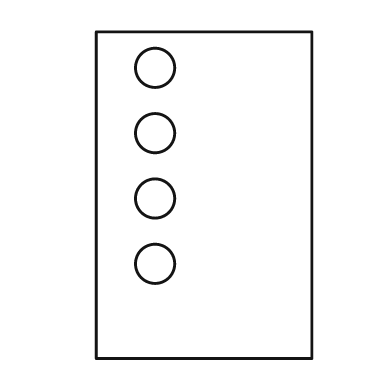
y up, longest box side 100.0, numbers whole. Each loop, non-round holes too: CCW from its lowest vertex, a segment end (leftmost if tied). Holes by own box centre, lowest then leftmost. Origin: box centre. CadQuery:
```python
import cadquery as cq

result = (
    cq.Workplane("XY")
    .moveTo(-33.0, -50.0)
    .lineTo(33.0, -50.0)
    .lineTo(33.0, 50.0)
    .lineTo(-33.0, 50.0)
    .close()
    .moveTo(-15.0, -21.0)
    .circle(6.0)
    .moveTo(-15.0, -1.0)
    .circle(6.0)
    .moveTo(-15.0, 19.0)
    .circle(6.0)
    .moveTo(-15.0, 39.0)
    .circle(6.0)
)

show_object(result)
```